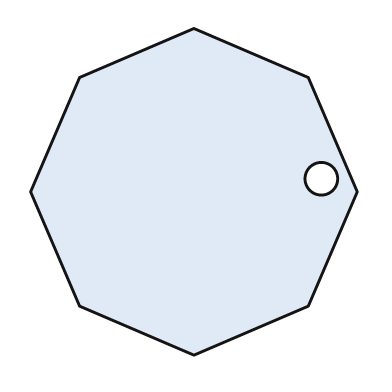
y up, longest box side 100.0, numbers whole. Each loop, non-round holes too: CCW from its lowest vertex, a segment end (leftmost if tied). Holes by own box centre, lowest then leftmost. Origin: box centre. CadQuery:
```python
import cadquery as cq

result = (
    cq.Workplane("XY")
    .moveTo(0.0, -50.0)
    .lineTo(35.0, -35.0)
    .lineTo(50.0, 0.0)
    .lineTo(35.0, 35.0)
    .lineTo(0.0, 50.0)
    .lineTo(-35.0, 35.0)
    .lineTo(-50.0, 0.0)
    .lineTo(-35.0, -35.0)
    .close()
    .moveTo(39.0, 4.0)
    .circle(5.0)
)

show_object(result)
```